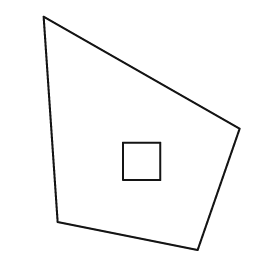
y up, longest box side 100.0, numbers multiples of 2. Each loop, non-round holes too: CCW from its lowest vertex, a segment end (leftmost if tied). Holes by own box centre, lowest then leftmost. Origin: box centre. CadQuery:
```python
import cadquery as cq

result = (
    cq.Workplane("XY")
    .moveTo(24.0, -50.0)
    .lineTo(42.0, 2.0)
    .lineTo(-42.0, 50.0)
    .lineTo(-36.0, -38.0)
    .close()
    .moveTo(-8.0, -20.0)
    .lineTo(8.0, -20.0)
    .lineTo(8.0, -4.0)
    .lineTo(-8.0, -4.0)
    .close()
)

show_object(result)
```